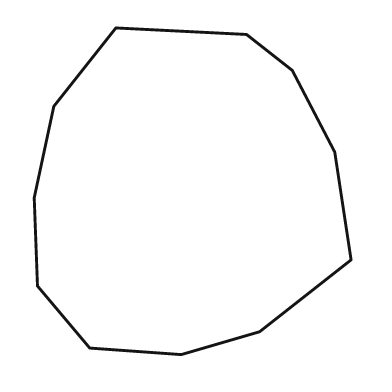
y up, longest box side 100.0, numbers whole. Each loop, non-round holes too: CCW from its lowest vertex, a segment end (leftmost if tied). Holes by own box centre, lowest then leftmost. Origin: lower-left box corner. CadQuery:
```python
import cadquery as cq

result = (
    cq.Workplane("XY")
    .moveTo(45.0, 0.0)
    .lineTo(69.0, 7.0)
    .lineTo(97.0, 29.0)
    .lineTo(92.0, 62.0)
    .lineTo(79.0, 87.0)
    .lineTo(65.0, 98.0)
    .lineTo(25.0, 100.0)
    .lineTo(6.0, 76.0)
    .lineTo(0.0, 48.0)
    .lineTo(1.0, 21.0)
    .lineTo(17.0, 2.0)
    .close()
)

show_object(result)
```